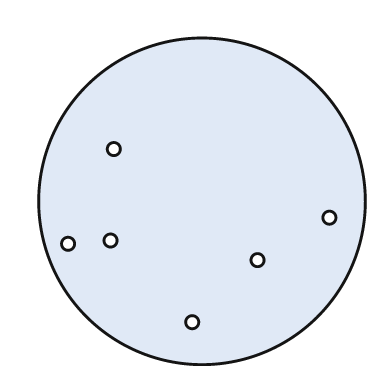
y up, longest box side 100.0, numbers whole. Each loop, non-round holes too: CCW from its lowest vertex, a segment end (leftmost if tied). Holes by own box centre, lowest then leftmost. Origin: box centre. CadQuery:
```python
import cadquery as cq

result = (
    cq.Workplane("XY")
    .moveTo(0.0, 0.0)
    .circle(50.0)
    .moveTo(-3.0, -37.0)
    .circle(2.0)
    .moveTo(17.0, -18.0)
    .circle(2.0)
    .moveTo(-41.0, -13.0)
    .circle(2.0)
    .moveTo(-28.0, -12.0)
    .circle(2.0)
    .moveTo(39.0, -5.0)
    .circle(2.0)
    .moveTo(-27.0, 16.0)
    .circle(2.0)
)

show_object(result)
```